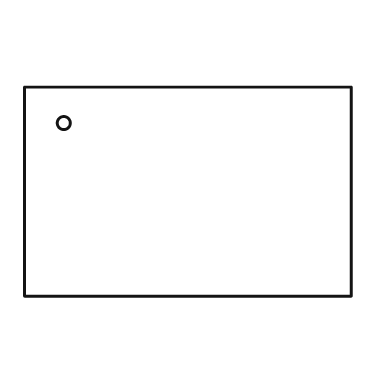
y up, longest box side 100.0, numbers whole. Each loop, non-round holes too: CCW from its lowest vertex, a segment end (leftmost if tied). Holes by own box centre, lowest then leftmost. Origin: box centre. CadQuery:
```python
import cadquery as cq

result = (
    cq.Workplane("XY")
    .moveTo(-50.0, -32.0)
    .lineTo(50.0, -32.0)
    .lineTo(50.0, 32.0)
    .lineTo(-50.0, 32.0)
    .close()
    .moveTo(-38.0, 21.0)
    .circle(2.0)
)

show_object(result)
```